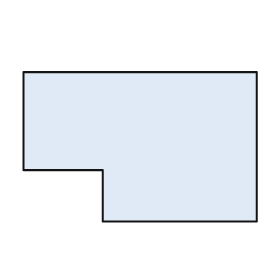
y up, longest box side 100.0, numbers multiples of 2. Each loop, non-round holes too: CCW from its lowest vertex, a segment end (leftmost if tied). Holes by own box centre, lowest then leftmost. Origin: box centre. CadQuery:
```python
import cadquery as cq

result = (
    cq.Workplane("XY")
    .moveTo(-16.0, -32.0)
    .lineTo(50.0, -32.0)
    .lineTo(50.0, 32.0)
    .lineTo(-50.0, 32.0)
    .lineTo(-50.0, -10.0)
    .lineTo(-16.0, -10.0)
    .close()
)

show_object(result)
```